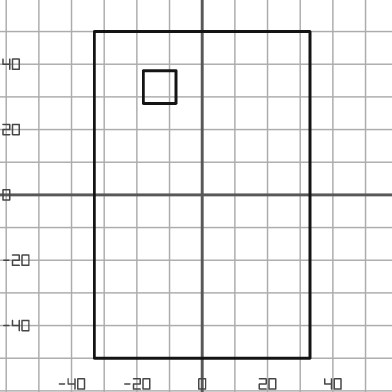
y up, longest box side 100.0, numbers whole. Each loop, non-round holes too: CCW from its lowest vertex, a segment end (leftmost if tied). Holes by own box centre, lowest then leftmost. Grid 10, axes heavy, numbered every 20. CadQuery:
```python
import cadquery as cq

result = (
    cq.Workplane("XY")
    .moveTo(-33.0, -50.0)
    .lineTo(33.0, -50.0)
    .lineTo(33.0, 50.0)
    .lineTo(-33.0, 50.0)
    .close()
    .moveTo(-18.0, 28.0)
    .lineTo(-8.0, 28.0)
    .lineTo(-8.0, 38.0)
    .lineTo(-18.0, 38.0)
    .close()
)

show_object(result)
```